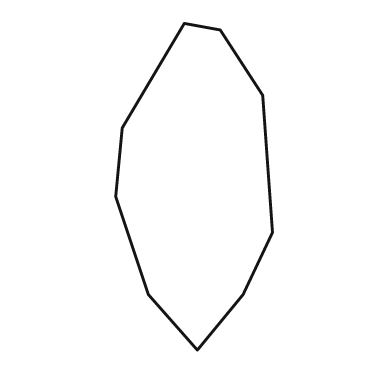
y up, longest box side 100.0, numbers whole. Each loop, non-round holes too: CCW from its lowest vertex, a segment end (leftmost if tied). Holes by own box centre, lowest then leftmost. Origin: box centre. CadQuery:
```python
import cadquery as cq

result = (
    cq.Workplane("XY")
    .moveTo(1.0, -50.0)
    .lineTo(15.0, -33.0)
    .lineTo(24.0, -14.0)
    .lineTo(21.0, 28.0)
    .lineTo(8.0, 48.0)
    .lineTo(-3.0, 50.0)
    .lineTo(-22.0, 18.0)
    .lineTo(-24.0, -3.0)
    .lineTo(-14.0, -33.0)
    .close()
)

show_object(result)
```